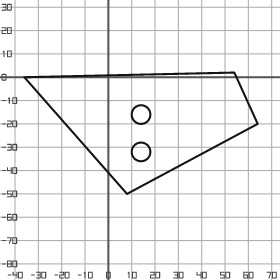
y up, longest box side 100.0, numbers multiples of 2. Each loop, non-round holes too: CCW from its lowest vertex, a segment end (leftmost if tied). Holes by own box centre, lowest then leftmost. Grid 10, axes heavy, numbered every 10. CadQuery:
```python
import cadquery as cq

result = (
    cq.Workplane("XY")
    .moveTo(8.0, -50.0)
    .lineTo(64.0, -20.0)
    .lineTo(54.0, 2.0)
    .lineTo(-36.0, 0.0)
    .close()
    .moveTo(14.0, -32.0)
    .circle(4.0)
    .moveTo(14.0, -16.0)
    .circle(4.0)
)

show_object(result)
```